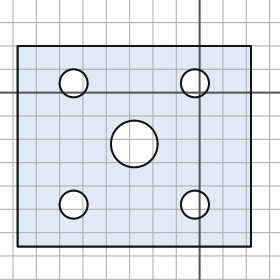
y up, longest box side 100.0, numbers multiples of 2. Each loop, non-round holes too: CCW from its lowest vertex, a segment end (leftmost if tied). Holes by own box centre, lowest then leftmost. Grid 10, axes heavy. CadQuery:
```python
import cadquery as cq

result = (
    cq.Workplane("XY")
    .moveTo(-78.0, -66.0)
    .lineTo(22.0, -66.0)
    .lineTo(22.0, 20.0)
    .lineTo(-78.0, 20.0)
    .close()
    .moveTo(-54.0, -48.0)
    .circle(6.0)
    .moveTo(-2.0, -48.0)
    .circle(6.0)
    .moveTo(-28.0, -22.0)
    .circle(10.0)
    .moveTo(-54.0, 4.0)
    .circle(6.0)
    .moveTo(-2.0, 4.0)
    .circle(6.0)
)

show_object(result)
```